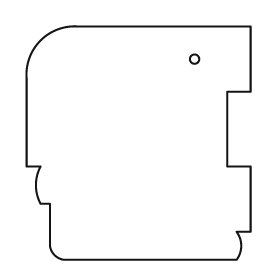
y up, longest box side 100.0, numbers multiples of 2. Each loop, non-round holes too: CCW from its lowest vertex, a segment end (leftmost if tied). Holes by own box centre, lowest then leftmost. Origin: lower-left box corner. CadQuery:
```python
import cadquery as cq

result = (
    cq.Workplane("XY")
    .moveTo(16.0, 0.0)
    .lineTo(90.0, 0.0)
    .threePointArc((92.0, 6.0), (90.0, 12.0))
    .lineTo(96.0, 12.0)
    .lineTo(96.0, 40.0)
    .lineTo(86.0, 40.0)
    .lineTo(86.0, 72.0)
    .lineTo(96.0, 72.0)
    .lineTo(96.0, 100.0)
    .lineTo(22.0, 100.0)
    .threePointArc((6.0, 94.0), (0.0, 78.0))
    .lineTo(0.0, 40.0)
    .lineTo(6.0, 40.0)
    .threePointArc((4.0, 32.0), (6.0, 24.0))
    .lineTo(10.0, 24.0)
    .lineTo(10.0, 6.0)
    .threePointArc((12.0, 2.0), (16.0, 0.0))
    .close()
    .moveTo(72.0, 86.0)
    .circle(2.0)
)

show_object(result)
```